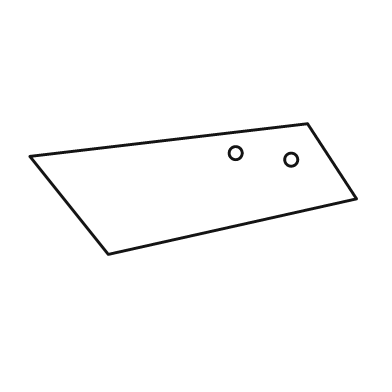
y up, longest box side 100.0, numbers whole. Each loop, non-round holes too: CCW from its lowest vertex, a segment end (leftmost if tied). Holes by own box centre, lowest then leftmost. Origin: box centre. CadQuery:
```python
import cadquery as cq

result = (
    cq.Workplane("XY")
    .moveTo(-26.0, -20.0)
    .lineTo(50.0, -3.0)
    .lineTo(35.0, 20.0)
    .lineTo(-50.0, 10.0)
    .close()
    .moveTo(30.0, 9.0)
    .circle(2.0)
    .moveTo(13.0, 11.0)
    .circle(2.0)
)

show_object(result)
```